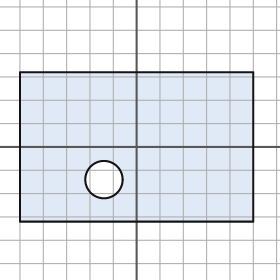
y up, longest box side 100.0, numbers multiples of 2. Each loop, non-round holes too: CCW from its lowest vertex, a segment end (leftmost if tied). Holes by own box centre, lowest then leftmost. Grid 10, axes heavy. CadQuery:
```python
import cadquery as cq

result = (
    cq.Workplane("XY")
    .moveTo(-50.0, -32.0)
    .lineTo(50.0, -32.0)
    .lineTo(50.0, 32.0)
    .lineTo(-50.0, 32.0)
    .close()
    .moveTo(-14.0, -14.0)
    .circle(8.0)
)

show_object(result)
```